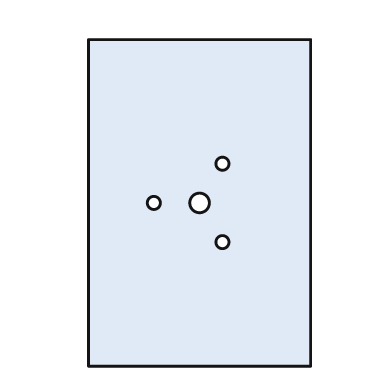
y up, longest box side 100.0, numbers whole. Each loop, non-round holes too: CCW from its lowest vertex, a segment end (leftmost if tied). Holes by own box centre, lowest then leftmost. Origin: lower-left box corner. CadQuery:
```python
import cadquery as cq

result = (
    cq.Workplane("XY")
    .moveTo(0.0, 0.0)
    .lineTo(68.0, 0.0)
    .lineTo(68.0, 100.0)
    .lineTo(0.0, 100.0)
    .close()
    .moveTo(41.0, 38.0)
    .circle(2.0)
    .moveTo(20.0, 50.0)
    .circle(2.0)
    .moveTo(34.0, 50.0)
    .circle(3.0)
    .moveTo(41.0, 62.0)
    .circle(2.0)
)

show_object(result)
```